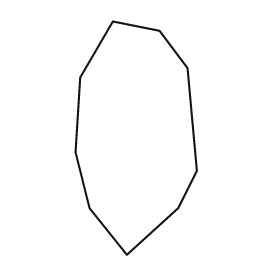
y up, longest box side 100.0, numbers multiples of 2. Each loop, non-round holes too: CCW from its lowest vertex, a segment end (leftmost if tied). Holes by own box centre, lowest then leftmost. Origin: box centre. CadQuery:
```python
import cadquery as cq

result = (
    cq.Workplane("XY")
    .moveTo(-4.0, -50.0)
    .lineTo(18.0, -30.0)
    .lineTo(26.0, -14.0)
    .lineTo(22.0, 30.0)
    .lineTo(10.0, 46.0)
    .lineTo(-10.0, 50.0)
    .lineTo(-24.0, 26.0)
    .lineTo(-26.0, -6.0)
    .lineTo(-20.0, -30.0)
    .close()
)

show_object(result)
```